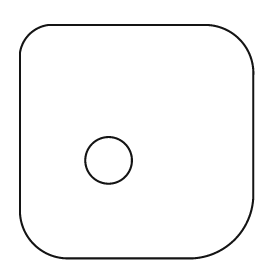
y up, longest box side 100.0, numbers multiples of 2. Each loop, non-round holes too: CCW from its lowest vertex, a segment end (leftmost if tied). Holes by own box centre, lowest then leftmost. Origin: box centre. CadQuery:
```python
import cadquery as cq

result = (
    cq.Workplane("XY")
    .moveTo(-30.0, -50.0)
    .lineTo(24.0, -50.0)
    .threePointArc((42.0, -42.0), (50.0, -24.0))
    .lineTo(50.0, 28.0)
    .threePointArc((44.0, 44.0), (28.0, 50.0))
    .lineTo(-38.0, 50.0)
    .threePointArc((-46.0, 46.0), (-50.0, 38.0))
    .lineTo(-50.0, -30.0)
    .threePointArc((-44.0, -44.0), (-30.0, -50.0))
    .close()
    .moveTo(-12.0, -8.0)
    .circle(10.0)
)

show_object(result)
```